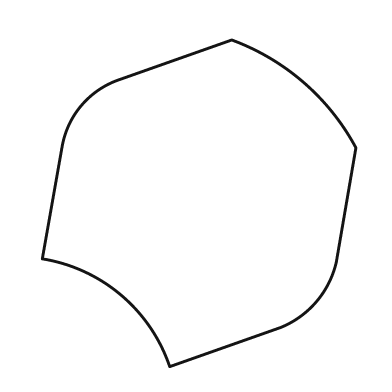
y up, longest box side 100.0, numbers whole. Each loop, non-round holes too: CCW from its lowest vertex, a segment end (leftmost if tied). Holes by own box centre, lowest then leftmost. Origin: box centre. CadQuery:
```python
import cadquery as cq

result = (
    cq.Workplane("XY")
    .moveTo(-9.0, -50.0)
    .lineTo(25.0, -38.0)
    .threePointArc((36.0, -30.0), (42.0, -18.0))
    .lineTo(48.0, 17.0)
    .threePointArc((32.0, 37.0), (10.0, 50.0))
    .lineTo(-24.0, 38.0)
    .threePointArc((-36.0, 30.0), (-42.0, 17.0))
    .lineTo(-48.0, -17.0)
    .threePointArc((-24.0, -28.0), (-9.0, -50.0))
    .close()
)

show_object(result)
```